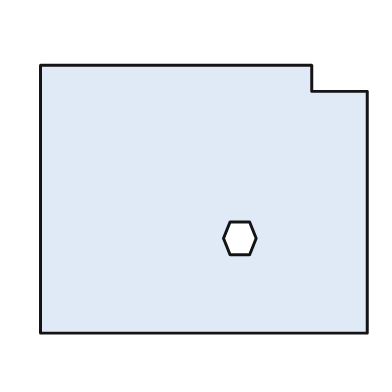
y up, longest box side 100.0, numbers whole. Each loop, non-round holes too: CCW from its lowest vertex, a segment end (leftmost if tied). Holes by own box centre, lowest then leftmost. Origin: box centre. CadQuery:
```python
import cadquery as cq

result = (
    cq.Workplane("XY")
    .moveTo(-50.0, -41.0)
    .lineTo(50.0, -41.0)
    .lineTo(50.0, 33.0)
    .lineTo(33.0, 33.0)
    .lineTo(33.0, 41.0)
    .lineTo(-50.0, 41.0)
    .close()
    .moveTo(8.0, -17.0)
    .lineTo(14.0, -17.0)
    .lineTo(16.0, -12.0)
    .lineTo(14.0, -7.0)
    .lineTo(8.0, -7.0)
    .lineTo(6.0, -12.0)
    .close()
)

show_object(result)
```